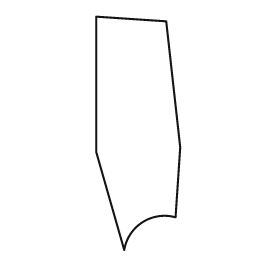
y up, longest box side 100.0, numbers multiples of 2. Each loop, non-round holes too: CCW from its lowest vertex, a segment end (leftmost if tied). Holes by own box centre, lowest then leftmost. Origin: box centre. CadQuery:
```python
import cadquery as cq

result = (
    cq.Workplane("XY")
    .moveTo(-6.0, -50.0)
    .threePointArc((2.0, -38.0), (16.0, -36.0))
    .lineTo(18.0, -6.0)
    .lineTo(12.0, 48.0)
    .lineTo(-18.0, 50.0)
    .lineTo(-18.0, -8.0)
    .close()
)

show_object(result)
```